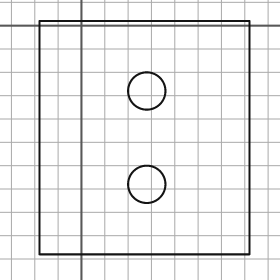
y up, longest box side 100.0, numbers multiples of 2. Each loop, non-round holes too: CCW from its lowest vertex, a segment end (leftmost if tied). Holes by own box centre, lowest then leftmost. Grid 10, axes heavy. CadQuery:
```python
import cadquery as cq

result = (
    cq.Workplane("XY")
    .moveTo(-18.0, -98.0)
    .lineTo(72.0, -98.0)
    .lineTo(72.0, 2.0)
    .lineTo(-18.0, 2.0)
    .close()
    .moveTo(28.0, -68.0)
    .circle(8.0)
    .moveTo(28.0, -28.0)
    .circle(8.0)
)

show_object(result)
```